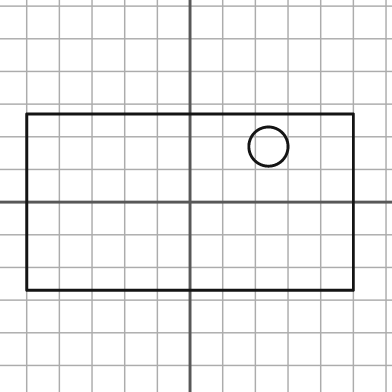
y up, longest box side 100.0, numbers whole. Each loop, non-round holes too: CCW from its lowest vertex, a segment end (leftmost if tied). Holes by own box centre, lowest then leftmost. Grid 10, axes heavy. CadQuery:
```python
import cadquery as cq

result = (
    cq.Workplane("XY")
    .moveTo(-50.0, -27.0)
    .lineTo(50.0, -27.0)
    .lineTo(50.0, 27.0)
    .lineTo(-50.0, 27.0)
    .close()
    .moveTo(24.0, 17.0)
    .circle(6.0)
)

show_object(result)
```